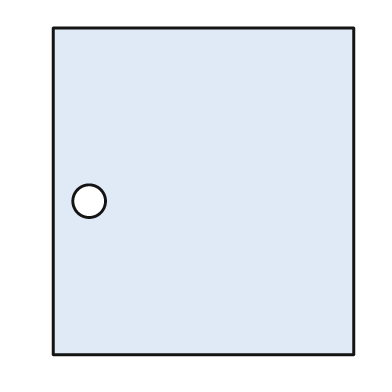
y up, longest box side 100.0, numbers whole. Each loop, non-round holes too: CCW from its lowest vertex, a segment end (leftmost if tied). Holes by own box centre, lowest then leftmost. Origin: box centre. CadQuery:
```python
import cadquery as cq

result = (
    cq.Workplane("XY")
    .moveTo(-46.0, -50.0)
    .lineTo(46.0, -50.0)
    .lineTo(46.0, 50.0)
    .lineTo(-46.0, 50.0)
    .close()
    .moveTo(-35.0, -3.0)
    .circle(5.0)
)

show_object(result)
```